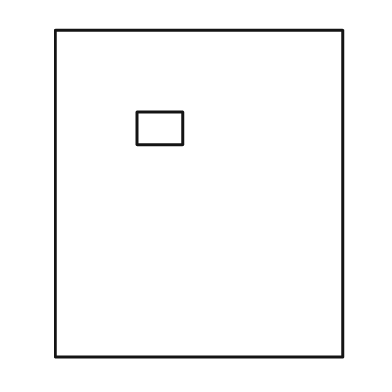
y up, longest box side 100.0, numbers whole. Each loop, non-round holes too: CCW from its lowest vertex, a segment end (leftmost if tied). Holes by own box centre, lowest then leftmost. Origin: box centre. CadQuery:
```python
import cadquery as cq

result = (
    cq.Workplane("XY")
    .moveTo(-44.0, -50.0)
    .lineTo(44.0, -50.0)
    .lineTo(44.0, 50.0)
    .lineTo(-44.0, 50.0)
    .close()
    .moveTo(-19.0, 15.0)
    .lineTo(-5.0, 15.0)
    .lineTo(-5.0, 25.0)
    .lineTo(-19.0, 25.0)
    .close()
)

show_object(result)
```